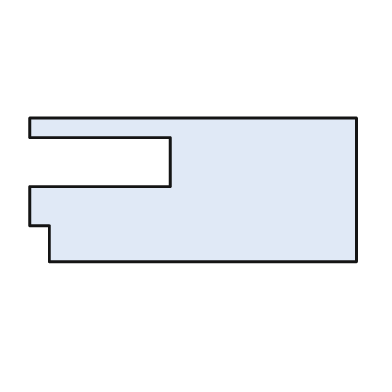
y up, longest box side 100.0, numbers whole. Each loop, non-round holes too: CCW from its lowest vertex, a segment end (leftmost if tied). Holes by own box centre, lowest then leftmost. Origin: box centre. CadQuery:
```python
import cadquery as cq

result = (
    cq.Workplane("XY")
    .moveTo(-44.0, -22.0)
    .lineTo(50.0, -22.0)
    .lineTo(50.0, 22.0)
    .lineTo(-50.0, 22.0)
    .lineTo(-50.0, 16.0)
    .lineTo(-7.0, 16.0)
    .lineTo(-7.0, 1.0)
    .lineTo(-50.0, 1.0)
    .lineTo(-50.0, -11.0)
    .lineTo(-44.0, -11.0)
    .close()
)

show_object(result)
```